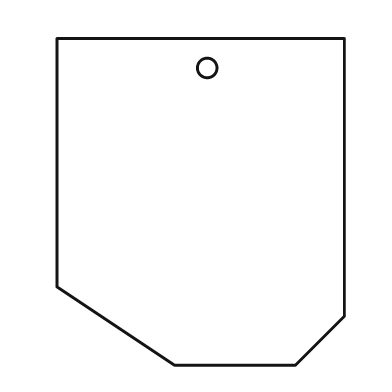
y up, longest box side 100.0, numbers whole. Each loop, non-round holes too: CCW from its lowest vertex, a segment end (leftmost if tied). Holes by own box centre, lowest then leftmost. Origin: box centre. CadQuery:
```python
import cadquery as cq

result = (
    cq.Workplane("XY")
    .moveTo(-8.0, -50.0)
    .lineTo(29.0, -50.0)
    .lineTo(44.0, -35.0)
    .lineTo(44.0, 50.0)
    .lineTo(-44.0, 50.0)
    .lineTo(-44.0, -26.0)
    .close()
    .moveTo(2.0, 41.0)
    .circle(3.0)
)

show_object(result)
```